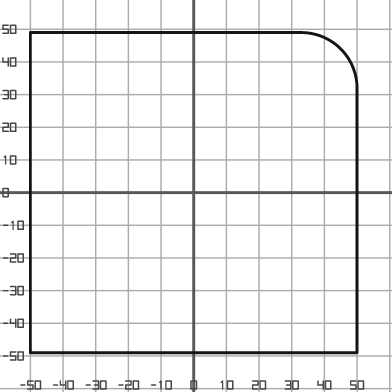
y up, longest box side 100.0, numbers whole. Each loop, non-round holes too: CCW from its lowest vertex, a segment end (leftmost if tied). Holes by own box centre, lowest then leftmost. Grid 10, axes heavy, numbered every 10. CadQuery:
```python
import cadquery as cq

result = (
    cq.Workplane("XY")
    .moveTo(-50.0, -49.0)
    .lineTo(50.0, -49.0)
    .lineTo(50.0, 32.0)
    .threePointArc((45.0, 44.0), (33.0, 49.0))
    .lineTo(-50.0, 49.0)
    .close()
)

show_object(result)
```